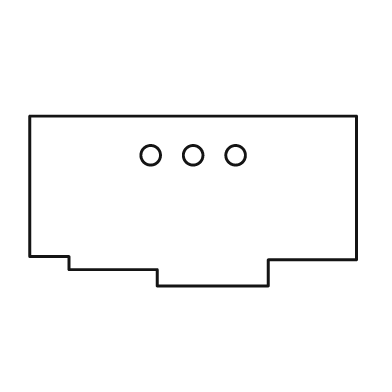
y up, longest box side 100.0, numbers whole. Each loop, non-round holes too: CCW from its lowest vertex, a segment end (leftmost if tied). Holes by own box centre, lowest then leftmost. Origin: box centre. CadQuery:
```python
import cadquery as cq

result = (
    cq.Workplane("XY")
    .moveTo(-11.0, -26.0)
    .lineTo(23.0, -26.0)
    .lineTo(23.0, -18.0)
    .lineTo(50.0, -18.0)
    .lineTo(50.0, 26.0)
    .lineTo(-50.0, 26.0)
    .lineTo(-50.0, -17.0)
    .lineTo(-38.0, -17.0)
    .lineTo(-38.0, -21.0)
    .lineTo(-11.0, -21.0)
    .close()
    .moveTo(-13.0, 14.0)
    .circle(3.0)
    .moveTo(0.0, 14.0)
    .circle(3.0)
    .moveTo(13.0, 14.0)
    .circle(3.0)
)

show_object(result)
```